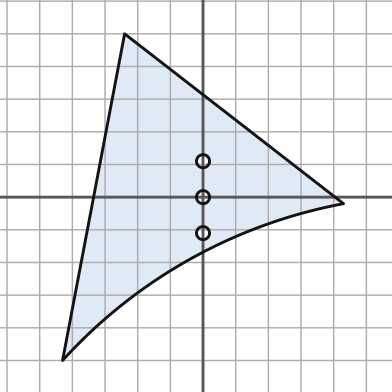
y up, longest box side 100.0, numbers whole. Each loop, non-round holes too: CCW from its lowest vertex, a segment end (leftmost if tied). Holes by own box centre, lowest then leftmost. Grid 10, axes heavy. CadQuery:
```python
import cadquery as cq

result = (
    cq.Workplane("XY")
    .moveTo(-43.0, -50.0)
    .threePointArc((-4.0, -19.0), (43.0, -2.0))
    .lineTo(-24.0, 50.0)
    .close()
    .moveTo(0.0, -11.0)
    .circle(2.0)
    .moveTo(0.0, 0.0)
    .circle(2.0)
    .moveTo(0.0, 11.0)
    .circle(2.0)
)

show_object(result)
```